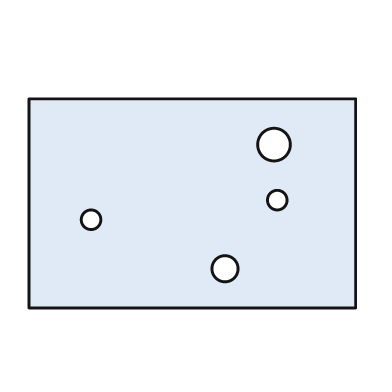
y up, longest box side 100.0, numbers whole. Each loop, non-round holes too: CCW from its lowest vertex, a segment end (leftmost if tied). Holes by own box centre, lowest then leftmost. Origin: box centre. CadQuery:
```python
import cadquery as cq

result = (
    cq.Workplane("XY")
    .moveTo(-50.0, -32.0)
    .lineTo(50.0, -32.0)
    .lineTo(50.0, 32.0)
    .lineTo(-50.0, 32.0)
    .close()
    .moveTo(10.0, -20.0)
    .circle(4.0)
    .moveTo(-31.0, -5.0)
    .circle(3.0)
    .moveTo(26.0, 1.0)
    .circle(3.0)
    .moveTo(25.0, 18.0)
    .circle(5.0)
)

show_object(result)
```